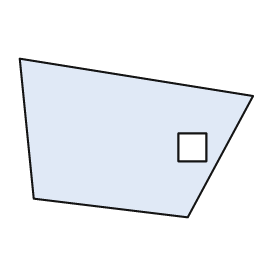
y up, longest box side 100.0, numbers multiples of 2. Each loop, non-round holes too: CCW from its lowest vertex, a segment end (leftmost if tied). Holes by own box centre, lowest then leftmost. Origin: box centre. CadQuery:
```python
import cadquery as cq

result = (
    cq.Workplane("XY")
    .moveTo(22.0, -34.0)
    .lineTo(50.0, 18.0)
    .lineTo(-50.0, 34.0)
    .lineTo(-44.0, -26.0)
    .close()
    .moveTo(18.0, -10.0)
    .lineTo(30.0, -10.0)
    .lineTo(30.0, 2.0)
    .lineTo(18.0, 2.0)
    .close()
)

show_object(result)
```